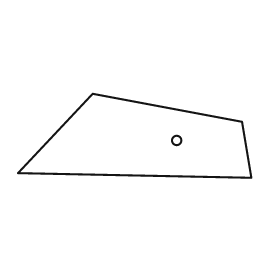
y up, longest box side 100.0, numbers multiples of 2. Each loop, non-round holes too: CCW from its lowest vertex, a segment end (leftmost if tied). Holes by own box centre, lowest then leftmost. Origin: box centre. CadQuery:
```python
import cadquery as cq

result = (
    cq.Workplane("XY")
    .moveTo(50.0, -18.0)
    .lineTo(46.0, 6.0)
    .lineTo(-18.0, 18.0)
    .lineTo(-50.0, -16.0)
    .close()
    .moveTo(18.0, -2.0)
    .circle(2.0)
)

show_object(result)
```